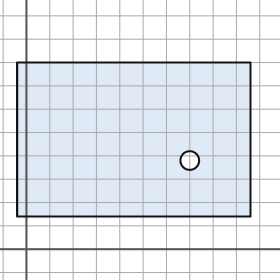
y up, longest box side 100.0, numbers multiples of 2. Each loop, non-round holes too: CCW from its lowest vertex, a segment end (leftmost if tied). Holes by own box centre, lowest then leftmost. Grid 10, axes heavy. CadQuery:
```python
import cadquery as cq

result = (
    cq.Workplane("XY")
    .moveTo(-4.0, 14.0)
    .lineTo(96.0, 14.0)
    .lineTo(96.0, 80.0)
    .lineTo(-4.0, 80.0)
    .close()
    .moveTo(70.0, 38.0)
    .circle(4.0)
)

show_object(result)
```